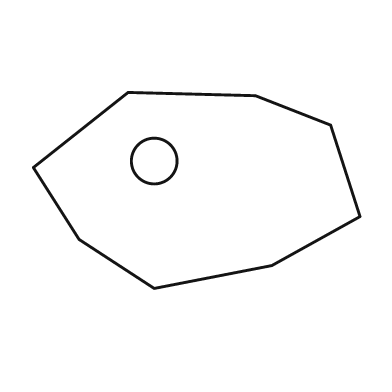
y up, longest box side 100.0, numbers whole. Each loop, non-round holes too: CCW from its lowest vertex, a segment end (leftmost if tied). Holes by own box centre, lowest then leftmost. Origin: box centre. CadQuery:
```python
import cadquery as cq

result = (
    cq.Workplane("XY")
    .moveTo(-13.0, -30.0)
    .lineTo(23.0, -23.0)
    .lineTo(50.0, -8.0)
    .lineTo(41.0, 20.0)
    .lineTo(18.0, 29.0)
    .lineTo(-21.0, 30.0)
    .lineTo(-50.0, 7.0)
    .lineTo(-36.0, -15.0)
    .close()
    .moveTo(-13.0, 9.0)
    .circle(7.0)
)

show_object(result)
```